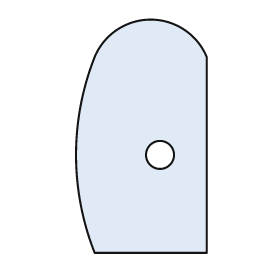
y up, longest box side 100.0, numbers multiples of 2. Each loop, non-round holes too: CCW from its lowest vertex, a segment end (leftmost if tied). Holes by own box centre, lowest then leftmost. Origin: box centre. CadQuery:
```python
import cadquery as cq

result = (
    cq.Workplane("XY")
    .moveTo(-20.0, -50.0)
    .lineTo(28.0, -50.0)
    .lineTo(28.0, 34.0)
    .threePointArc((4.0, 50.0), (-20.0, 34.0))
    .threePointArc((-28.0, -8.0), (-20.0, -50.0))
    .close()
    .moveTo(8.0, -8.0)
    .circle(6.0)
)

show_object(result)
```